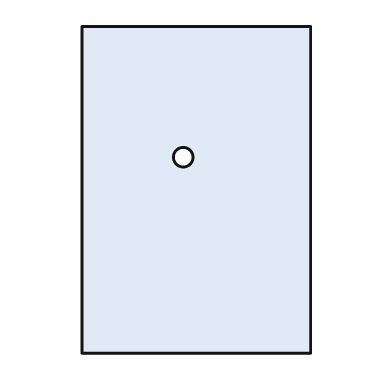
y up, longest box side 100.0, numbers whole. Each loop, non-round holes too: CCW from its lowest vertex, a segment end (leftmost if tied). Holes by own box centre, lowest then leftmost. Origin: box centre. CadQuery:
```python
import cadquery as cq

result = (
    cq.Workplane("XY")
    .moveTo(-35.0, -50.0)
    .lineTo(35.0, -50.0)
    .lineTo(35.0, 50.0)
    .lineTo(-35.0, 50.0)
    .close()
    .moveTo(-4.0, 10.0)
    .circle(3.0)
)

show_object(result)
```